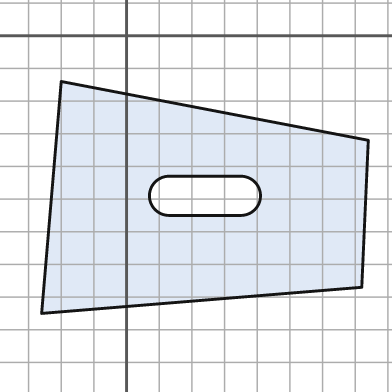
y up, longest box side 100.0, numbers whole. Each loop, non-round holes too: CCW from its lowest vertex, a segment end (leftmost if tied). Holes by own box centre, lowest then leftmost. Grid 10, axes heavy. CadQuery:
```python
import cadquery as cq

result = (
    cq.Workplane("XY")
    .moveTo(-26.0, -85.0)
    .lineTo(72.0, -77.0)
    .lineTo(74.0, -32.0)
    .lineTo(-20.0, -14.0)
    .close()
    .moveTo(13.0, -55.0)
    .lineTo(35.0, -55.0)
    .threePointArc((41.0, -49.0), (35.0, -43.0))
    .lineTo(13.0, -43.0)
    .threePointArc((7.0, -49.0), (13.0, -55.0))
    .close()
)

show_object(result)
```